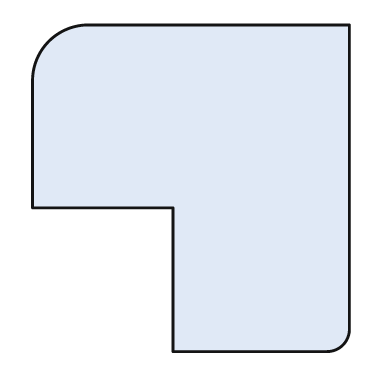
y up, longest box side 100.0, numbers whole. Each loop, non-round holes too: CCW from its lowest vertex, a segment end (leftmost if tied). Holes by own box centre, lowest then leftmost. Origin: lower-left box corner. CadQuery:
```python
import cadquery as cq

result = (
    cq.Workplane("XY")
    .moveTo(43.0, 0.0)
    .lineTo(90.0, 0.0)
    .threePointArc((95.0, 2.0), (97.0, 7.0))
    .lineTo(97.0, 100.0)
    .lineTo(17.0, 100.0)
    .threePointArc((5.0, 95.0), (0.0, 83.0))
    .lineTo(0.0, 44.0)
    .lineTo(43.0, 44.0)
    .close()
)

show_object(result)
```